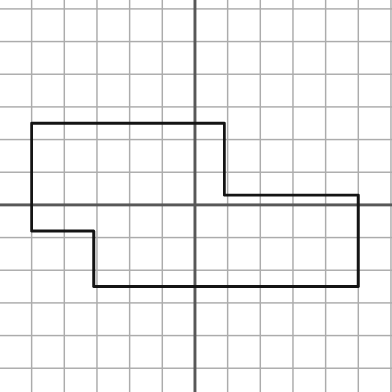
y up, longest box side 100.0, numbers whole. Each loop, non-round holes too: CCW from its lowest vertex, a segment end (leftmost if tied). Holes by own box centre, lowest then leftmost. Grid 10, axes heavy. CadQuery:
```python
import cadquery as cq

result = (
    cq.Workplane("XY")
    .moveTo(-31.0, -25.0)
    .lineTo(50.0, -25.0)
    .lineTo(50.0, 3.0)
    .lineTo(9.0, 3.0)
    .lineTo(9.0, 25.0)
    .lineTo(-50.0, 25.0)
    .lineTo(-50.0, -8.0)
    .lineTo(-31.0, -8.0)
    .close()
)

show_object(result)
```